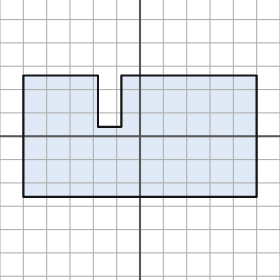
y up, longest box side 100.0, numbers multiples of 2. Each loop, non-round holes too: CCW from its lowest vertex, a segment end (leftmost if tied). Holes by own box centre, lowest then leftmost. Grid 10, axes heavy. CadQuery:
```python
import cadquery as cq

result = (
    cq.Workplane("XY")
    .moveTo(-50.0, -26.0)
    .lineTo(50.0, -26.0)
    .lineTo(50.0, 26.0)
    .lineTo(-8.0, 26.0)
    .lineTo(-8.0, 4.0)
    .lineTo(-18.0, 4.0)
    .lineTo(-18.0, 26.0)
    .lineTo(-50.0, 26.0)
    .close()
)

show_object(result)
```